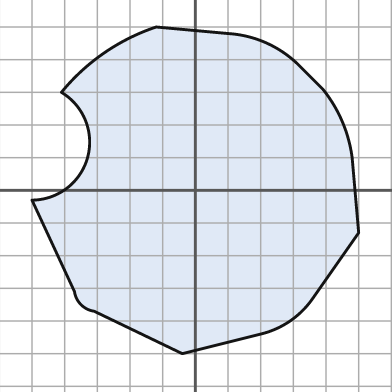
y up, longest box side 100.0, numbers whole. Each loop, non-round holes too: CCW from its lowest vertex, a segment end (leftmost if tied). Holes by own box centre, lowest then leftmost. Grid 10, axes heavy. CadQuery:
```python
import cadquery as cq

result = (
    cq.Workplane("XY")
    .moveTo(-4.0, -50.0)
    .lineTo(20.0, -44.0)
    .threePointArc((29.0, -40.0), (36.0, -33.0))
    .lineTo(50.0, -13.0)
    .lineTo(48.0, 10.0)
    .threePointArc((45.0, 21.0), (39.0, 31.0))
    .lineTo(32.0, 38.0)
    .threePointArc((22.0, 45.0), (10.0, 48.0))
    .lineTo(-12.0, 50.0)
    .threePointArc((-28.0, 42.0), (-41.0, 30.0))
    .threePointArc((-33.0, 10.0), (-50.0, -3.0))
    .lineTo(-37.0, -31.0)
    .threePointArc((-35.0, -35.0), (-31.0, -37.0))
    .close()
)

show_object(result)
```